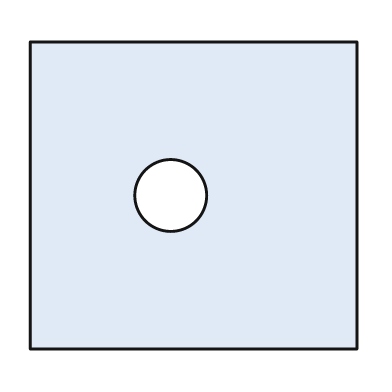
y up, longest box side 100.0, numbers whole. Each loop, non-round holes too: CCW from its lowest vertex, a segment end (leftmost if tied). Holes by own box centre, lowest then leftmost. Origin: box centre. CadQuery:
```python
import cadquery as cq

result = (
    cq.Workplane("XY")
    .moveTo(-50.0, -47.0)
    .lineTo(50.0, -47.0)
    .lineTo(50.0, 47.0)
    .lineTo(-50.0, 47.0)
    .close()
    .moveTo(-7.0, 0.0)
    .circle(11.0)
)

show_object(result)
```